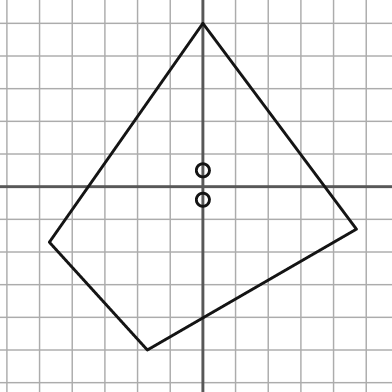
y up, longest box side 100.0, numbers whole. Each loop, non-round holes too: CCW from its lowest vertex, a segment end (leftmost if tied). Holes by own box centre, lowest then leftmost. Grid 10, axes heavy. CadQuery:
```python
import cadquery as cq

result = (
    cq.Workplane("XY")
    .moveTo(-17.0, -50.0)
    .lineTo(47.0, -13.0)
    .lineTo(0.0, 50.0)
    .lineTo(-47.0, -17.0)
    .close()
    .moveTo(0.0, -4.0)
    .circle(2.0)
    .moveTo(0.0, 5.0)
    .circle(2.0)
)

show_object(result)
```